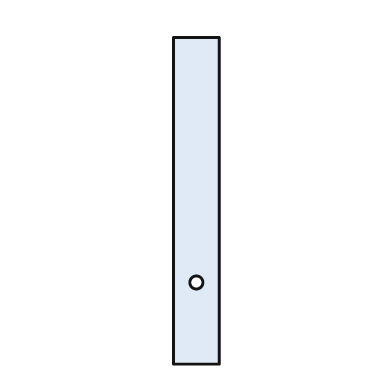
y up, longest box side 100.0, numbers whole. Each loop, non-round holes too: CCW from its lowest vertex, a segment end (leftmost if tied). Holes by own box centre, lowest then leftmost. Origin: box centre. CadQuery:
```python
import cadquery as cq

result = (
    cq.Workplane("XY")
    .moveTo(-7.0, -50.0)
    .lineTo(7.0, -50.0)
    .lineTo(7.0, 50.0)
    .lineTo(-7.0, 50.0)
    .close()
    .moveTo(0.0, -25.0)
    .circle(2.0)
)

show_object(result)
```